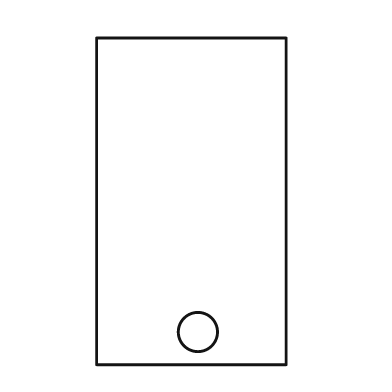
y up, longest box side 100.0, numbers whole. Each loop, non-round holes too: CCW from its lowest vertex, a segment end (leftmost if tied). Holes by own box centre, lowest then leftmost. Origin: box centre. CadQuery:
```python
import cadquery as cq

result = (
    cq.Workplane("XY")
    .moveTo(-29.0, -50.0)
    .lineTo(29.0, -50.0)
    .lineTo(29.0, 50.0)
    .lineTo(-29.0, 50.0)
    .close()
    .moveTo(2.0, -40.0)
    .circle(6.0)
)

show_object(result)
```